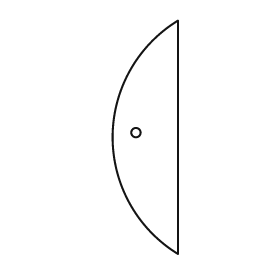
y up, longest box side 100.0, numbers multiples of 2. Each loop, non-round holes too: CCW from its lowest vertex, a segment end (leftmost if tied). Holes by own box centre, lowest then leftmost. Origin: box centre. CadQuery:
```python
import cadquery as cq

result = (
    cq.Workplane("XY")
    .moveTo(14.0, -50.0)
    .lineTo(14.0, 50.0)
    .threePointArc((-14.0, 0.0), (14.0, -50.0))
    .close()
    .moveTo(-4.0, 2.0)
    .circle(2.0)
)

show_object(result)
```